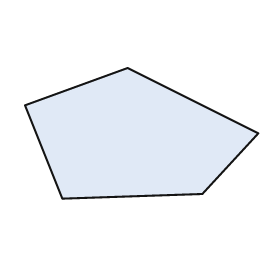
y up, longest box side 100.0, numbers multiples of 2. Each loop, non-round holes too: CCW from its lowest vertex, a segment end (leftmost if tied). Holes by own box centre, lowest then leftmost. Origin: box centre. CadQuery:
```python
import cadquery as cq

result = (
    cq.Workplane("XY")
    .moveTo(-34.0, -28.0)
    .lineTo(26.0, -26.0)
    .lineTo(50.0, 0.0)
    .lineTo(-6.0, 28.0)
    .lineTo(-50.0, 12.0)
    .close()
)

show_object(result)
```